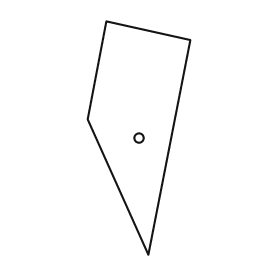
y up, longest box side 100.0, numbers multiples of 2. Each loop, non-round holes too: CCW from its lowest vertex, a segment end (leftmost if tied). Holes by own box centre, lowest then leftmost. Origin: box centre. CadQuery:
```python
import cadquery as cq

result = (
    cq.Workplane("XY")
    .moveTo(4.0, -50.0)
    .lineTo(22.0, 42.0)
    .lineTo(-14.0, 50.0)
    .lineTo(-22.0, 8.0)
    .close()
    .moveTo(0.0, 0.0)
    .circle(2.0)
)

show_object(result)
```